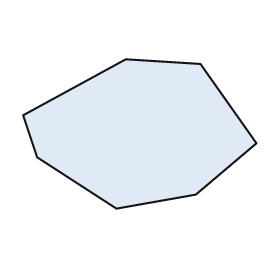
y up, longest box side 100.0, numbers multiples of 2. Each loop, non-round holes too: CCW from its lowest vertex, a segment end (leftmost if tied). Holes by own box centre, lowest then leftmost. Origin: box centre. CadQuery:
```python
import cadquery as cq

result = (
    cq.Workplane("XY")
    .moveTo(-10.0, -32.0)
    .lineTo(24.0, -26.0)
    .lineTo(50.0, -4.0)
    .lineTo(26.0, 30.0)
    .lineTo(-6.0, 32.0)
    .lineTo(-50.0, 8.0)
    .lineTo(-44.0, -10.0)
    .close()
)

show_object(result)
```